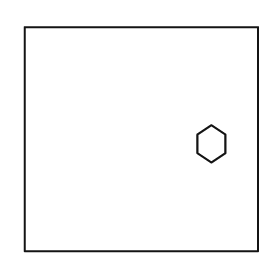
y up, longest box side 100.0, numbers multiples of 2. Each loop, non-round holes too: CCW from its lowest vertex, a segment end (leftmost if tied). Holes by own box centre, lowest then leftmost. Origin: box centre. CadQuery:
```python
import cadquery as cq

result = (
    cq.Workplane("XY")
    .moveTo(-50.0, -48.0)
    .lineTo(50.0, -48.0)
    .lineTo(50.0, 48.0)
    .lineTo(-50.0, 48.0)
    .close()
    .moveTo(30.0, -10.0)
    .lineTo(36.0, -6.0)
    .lineTo(36.0, 2.0)
    .lineTo(30.0, 6.0)
    .lineTo(24.0, 2.0)
    .lineTo(24.0, -6.0)
    .close()
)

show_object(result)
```